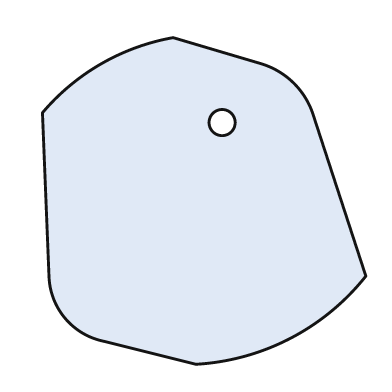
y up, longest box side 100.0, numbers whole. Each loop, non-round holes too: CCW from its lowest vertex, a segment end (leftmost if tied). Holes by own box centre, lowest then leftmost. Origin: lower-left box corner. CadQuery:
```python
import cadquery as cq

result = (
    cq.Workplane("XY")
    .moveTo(47.0, 0.0)
    .threePointArc((76.0, 8.0), (99.0, 27.0))
    .lineTo(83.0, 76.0)
    .threePointArc((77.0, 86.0), (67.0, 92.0))
    .lineTo(40.0, 100.0)
    .threePointArc((18.0, 92.0), (0.0, 77.0))
    .lineTo(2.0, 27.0)
    .threePointArc((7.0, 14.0), (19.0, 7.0))
    .close()
    .moveTo(55.0, 74.0)
    .circle(4.0)
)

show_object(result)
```